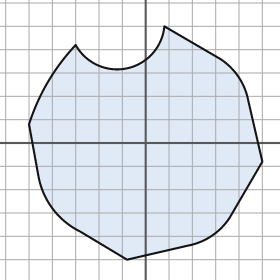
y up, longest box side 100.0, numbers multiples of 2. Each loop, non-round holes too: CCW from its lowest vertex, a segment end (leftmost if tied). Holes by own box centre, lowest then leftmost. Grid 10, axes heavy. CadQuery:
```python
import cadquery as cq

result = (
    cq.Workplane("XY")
    .moveTo(-8.0, -50.0)
    .lineTo(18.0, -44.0)
    .threePointArc((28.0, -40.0), (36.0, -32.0))
    .lineTo(50.0, -8.0)
    .lineTo(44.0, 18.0)
    .threePointArc((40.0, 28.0), (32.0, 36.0))
    .lineTo(8.0, 50.0)
    .threePointArc((-8.0, 32.0), (-30.0, 42.0))
    .threePointArc((-42.0, 26.0), (-50.0, 8.0))
    .lineTo(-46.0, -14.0)
    .threePointArc((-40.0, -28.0), (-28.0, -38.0))
    .close()
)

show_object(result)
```